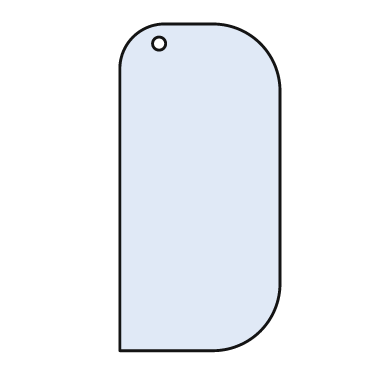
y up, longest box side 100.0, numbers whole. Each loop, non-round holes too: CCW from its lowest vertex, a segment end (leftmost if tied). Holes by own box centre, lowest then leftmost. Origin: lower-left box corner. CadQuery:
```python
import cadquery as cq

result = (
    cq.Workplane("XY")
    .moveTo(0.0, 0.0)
    .lineTo(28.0, 0.0)
    .threePointArc((43.0, 6.0), (49.0, 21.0))
    .lineTo(49.0, 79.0)
    .threePointArc((43.0, 94.0), (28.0, 100.0))
    .lineTo(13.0, 100.0)
    .threePointArc((4.0, 96.0), (0.0, 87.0))
    .close()
    .moveTo(12.0, 94.0)
    .circle(2.0)
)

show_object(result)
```